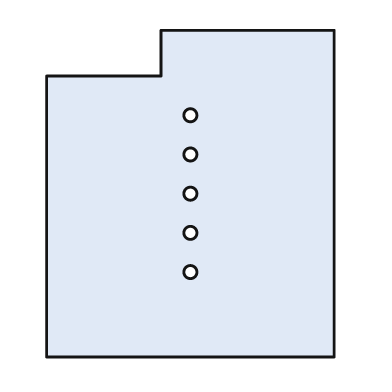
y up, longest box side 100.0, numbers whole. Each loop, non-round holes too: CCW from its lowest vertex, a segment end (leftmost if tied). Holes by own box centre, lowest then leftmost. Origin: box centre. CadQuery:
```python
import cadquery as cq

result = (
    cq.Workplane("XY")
    .moveTo(-44.0, -50.0)
    .lineTo(44.0, -50.0)
    .lineTo(44.0, 50.0)
    .lineTo(-9.0, 50.0)
    .lineTo(-9.0, 36.0)
    .lineTo(-44.0, 36.0)
    .close()
    .moveTo(0.0, -24.0)
    .circle(2.0)
    .moveTo(0.0, -12.0)
    .circle(2.0)
    .moveTo(0.0, 0.0)
    .circle(2.0)
    .moveTo(0.0, 12.0)
    .circle(2.0)
    .moveTo(0.0, 24.0)
    .circle(2.0)
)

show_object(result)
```